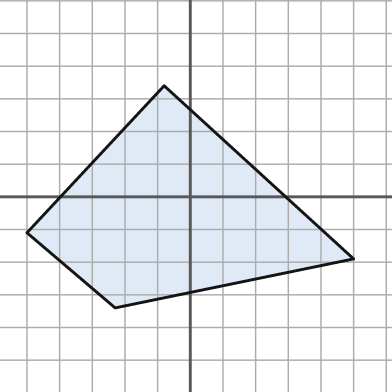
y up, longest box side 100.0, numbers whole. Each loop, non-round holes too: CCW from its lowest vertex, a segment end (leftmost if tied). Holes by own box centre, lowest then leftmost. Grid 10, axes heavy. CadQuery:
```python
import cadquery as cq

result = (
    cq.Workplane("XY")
    .moveTo(-23.0, -34.0)
    .lineTo(50.0, -19.0)
    .lineTo(-8.0, 34.0)
    .lineTo(-50.0, -11.0)
    .close()
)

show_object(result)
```